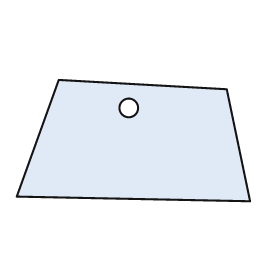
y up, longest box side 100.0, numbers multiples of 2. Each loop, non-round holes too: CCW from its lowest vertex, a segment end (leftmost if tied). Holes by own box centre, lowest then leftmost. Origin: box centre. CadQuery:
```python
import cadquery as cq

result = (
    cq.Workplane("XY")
    .moveTo(50.0, -26.0)
    .lineTo(40.0, 22.0)
    .lineTo(-32.0, 26.0)
    .lineTo(-50.0, -24.0)
    .close()
    .moveTo(-2.0, 14.0)
    .circle(4.0)
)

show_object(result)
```